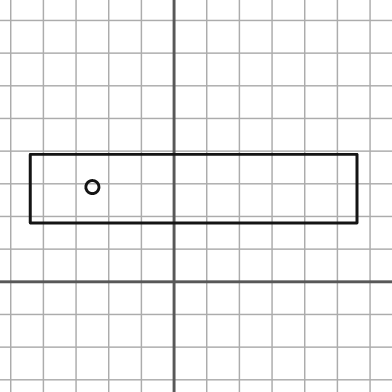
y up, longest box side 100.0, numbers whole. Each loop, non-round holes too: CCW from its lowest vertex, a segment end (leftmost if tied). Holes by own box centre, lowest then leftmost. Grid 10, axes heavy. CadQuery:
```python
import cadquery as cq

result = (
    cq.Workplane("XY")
    .moveTo(-44.0, 18.0)
    .lineTo(56.0, 18.0)
    .lineTo(56.0, 39.0)
    .lineTo(-44.0, 39.0)
    .close()
    .moveTo(-25.0, 29.0)
    .circle(2.0)
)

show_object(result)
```